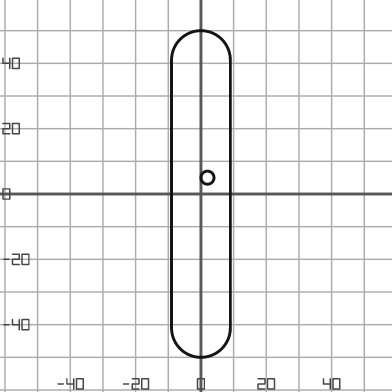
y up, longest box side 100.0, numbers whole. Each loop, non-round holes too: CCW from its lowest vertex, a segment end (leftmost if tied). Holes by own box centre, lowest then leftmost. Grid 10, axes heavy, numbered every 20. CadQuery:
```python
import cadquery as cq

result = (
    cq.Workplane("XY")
    .moveTo(-9.0, -41.0)
    .threePointArc((0.0, -50.0), (9.0, -41.0))
    .lineTo(9.0, 41.0)
    .threePointArc((0.0, 50.0), (-9.0, 41.0))
    .close()
    .moveTo(2.0, 5.0)
    .circle(2.0)
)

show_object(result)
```